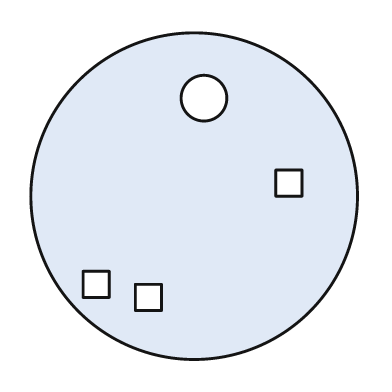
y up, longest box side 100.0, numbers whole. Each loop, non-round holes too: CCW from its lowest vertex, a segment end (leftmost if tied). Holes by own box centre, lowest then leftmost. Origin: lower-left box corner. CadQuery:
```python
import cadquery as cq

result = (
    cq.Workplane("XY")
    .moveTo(50.0, 50.0)
    .circle(50.0)
    .moveTo(32.0, 15.0)
    .lineTo(40.0, 15.0)
    .lineTo(40.0, 23.0)
    .lineTo(32.0, 23.0)
    .close()
    .moveTo(16.0, 19.0)
    .lineTo(24.0, 19.0)
    .lineTo(24.0, 27.0)
    .lineTo(16.0, 27.0)
    .close()
    .moveTo(75.0, 50.0)
    .lineTo(83.0, 50.0)
    .lineTo(83.0, 58.0)
    .lineTo(75.0, 58.0)
    .close()
    .moveTo(53.0, 80.0)
    .circle(7.0)
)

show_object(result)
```